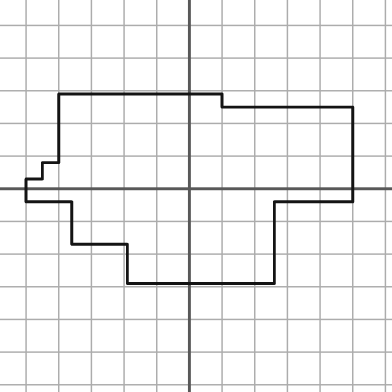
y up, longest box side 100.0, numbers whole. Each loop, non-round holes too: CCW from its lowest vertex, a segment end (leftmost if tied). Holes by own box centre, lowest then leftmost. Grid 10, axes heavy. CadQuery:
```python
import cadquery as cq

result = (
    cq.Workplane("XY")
    .moveTo(-19.0, -29.0)
    .lineTo(26.0, -29.0)
    .lineTo(26.0, -4.0)
    .lineTo(50.0, -4.0)
    .lineTo(50.0, 25.0)
    .lineTo(10.0, 25.0)
    .lineTo(10.0, 29.0)
    .lineTo(-40.0, 29.0)
    .lineTo(-40.0, 8.0)
    .lineTo(-45.0, 8.0)
    .lineTo(-45.0, 3.0)
    .lineTo(-50.0, 3.0)
    .lineTo(-50.0, -4.0)
    .lineTo(-36.0, -4.0)
    .lineTo(-36.0, -17.0)
    .lineTo(-19.0, -17.0)
    .close()
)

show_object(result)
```